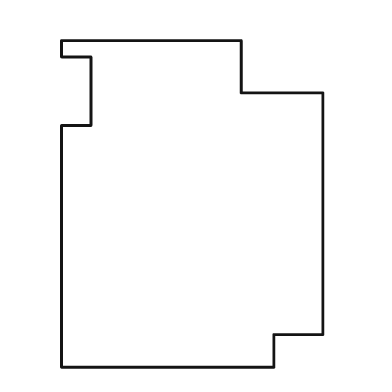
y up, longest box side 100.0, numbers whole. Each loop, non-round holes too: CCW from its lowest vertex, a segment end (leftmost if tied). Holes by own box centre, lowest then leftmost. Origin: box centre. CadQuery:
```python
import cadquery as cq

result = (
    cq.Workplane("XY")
    .moveTo(-40.0, -50.0)
    .lineTo(25.0, -50.0)
    .lineTo(25.0, -40.0)
    .lineTo(40.0, -40.0)
    .lineTo(40.0, 34.0)
    .lineTo(15.0, 34.0)
    .lineTo(15.0, 50.0)
    .lineTo(-40.0, 50.0)
    .lineTo(-40.0, 45.0)
    .lineTo(-31.0, 45.0)
    .lineTo(-31.0, 24.0)
    .lineTo(-40.0, 24.0)
    .close()
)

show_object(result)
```